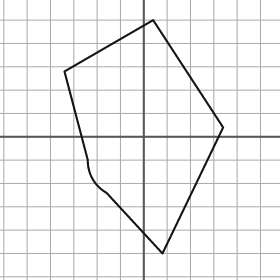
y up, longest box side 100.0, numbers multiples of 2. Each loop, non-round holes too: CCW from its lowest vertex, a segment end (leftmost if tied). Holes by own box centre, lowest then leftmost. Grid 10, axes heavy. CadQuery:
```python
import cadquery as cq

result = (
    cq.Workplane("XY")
    .moveTo(8.0, -50.0)
    .lineTo(34.0, 4.0)
    .lineTo(4.0, 50.0)
    .lineTo(-34.0, 28.0)
    .lineTo(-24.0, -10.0)
    .threePointArc((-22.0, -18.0), (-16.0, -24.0))
    .close()
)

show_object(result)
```